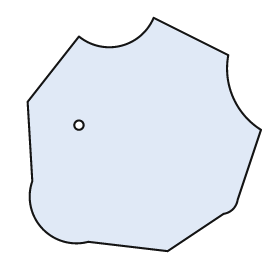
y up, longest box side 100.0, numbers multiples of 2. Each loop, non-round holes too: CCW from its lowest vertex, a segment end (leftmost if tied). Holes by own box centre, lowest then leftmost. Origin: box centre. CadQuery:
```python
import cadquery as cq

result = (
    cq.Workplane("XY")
    .moveTo(10.0, -50.0)
    .lineTo(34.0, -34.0)
    .threePointArc((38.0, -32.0), (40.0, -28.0))
    .lineTo(50.0, 2.0)
    .threePointArc((38.0, 16.0), (36.0, 34.0))
    .lineTo(4.0, 50.0)
    .threePointArc((-10.0, 38.0), (-28.0, 42.0))
    .lineTo(-50.0, 14.0)
    .lineTo(-48.0, -20.0)
    .threePointArc((-44.0, -40.0), (-24.0, -46.0))
    .close()
    .moveTo(-28.0, 4.0)
    .circle(2.0)
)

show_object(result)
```